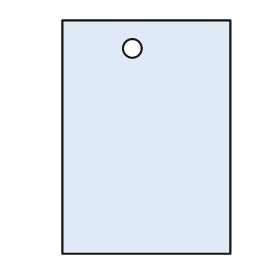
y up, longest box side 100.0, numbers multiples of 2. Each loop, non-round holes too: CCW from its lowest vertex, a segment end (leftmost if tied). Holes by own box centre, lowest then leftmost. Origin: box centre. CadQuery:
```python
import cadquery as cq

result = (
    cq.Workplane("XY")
    .moveTo(-36.0, -50.0)
    .lineTo(36.0, -50.0)
    .lineTo(36.0, 50.0)
    .lineTo(-36.0, 50.0)
    .close()
    .moveTo(-6.0, 38.0)
    .circle(4.0)
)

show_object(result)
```